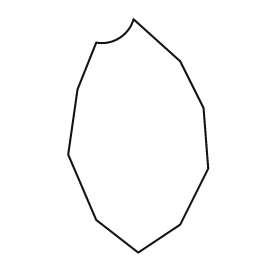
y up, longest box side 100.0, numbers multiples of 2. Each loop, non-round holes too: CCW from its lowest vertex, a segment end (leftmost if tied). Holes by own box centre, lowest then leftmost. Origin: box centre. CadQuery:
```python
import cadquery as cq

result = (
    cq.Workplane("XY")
    .moveTo(0.0, -50.0)
    .lineTo(18.0, -38.0)
    .lineTo(30.0, -14.0)
    .lineTo(28.0, 12.0)
    .lineTo(18.0, 32.0)
    .lineTo(-2.0, 50.0)
    .threePointArc((-8.0, 42.0), (-18.0, 40.0))
    .lineTo(-26.0, 20.0)
    .lineTo(-30.0, -8.0)
    .lineTo(-18.0, -36.0)
    .close()
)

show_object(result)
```